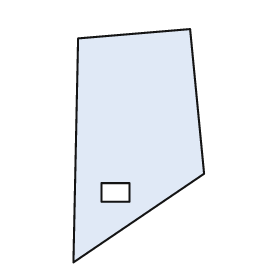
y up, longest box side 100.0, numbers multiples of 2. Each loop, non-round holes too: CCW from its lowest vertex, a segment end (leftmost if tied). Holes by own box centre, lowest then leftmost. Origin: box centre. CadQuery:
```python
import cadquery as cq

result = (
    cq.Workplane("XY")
    .moveTo(-28.0, -50.0)
    .lineTo(28.0, -12.0)
    .lineTo(22.0, 50.0)
    .lineTo(-26.0, 46.0)
    .close()
    .moveTo(-16.0, -24.0)
    .lineTo(-4.0, -24.0)
    .lineTo(-4.0, -16.0)
    .lineTo(-16.0, -16.0)
    .close()
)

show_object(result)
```